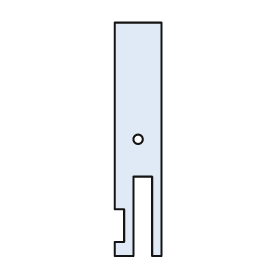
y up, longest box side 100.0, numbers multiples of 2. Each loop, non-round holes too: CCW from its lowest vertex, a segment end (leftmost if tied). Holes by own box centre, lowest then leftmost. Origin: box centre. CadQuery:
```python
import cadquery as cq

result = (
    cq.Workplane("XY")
    .moveTo(-10.0, -50.0)
    .lineTo(-2.0, -50.0)
    .lineTo(-2.0, -16.0)
    .lineTo(6.0, -16.0)
    .lineTo(6.0, -50.0)
    .lineTo(10.0, -50.0)
    .lineTo(10.0, 50.0)
    .lineTo(-10.0, 50.0)
    .lineTo(-10.0, -30.0)
    .lineTo(-6.0, -30.0)
    .lineTo(-6.0, -44.0)
    .lineTo(-10.0, -44.0)
    .close()
    .moveTo(0.0, 0.0)
    .circle(2.0)
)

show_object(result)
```